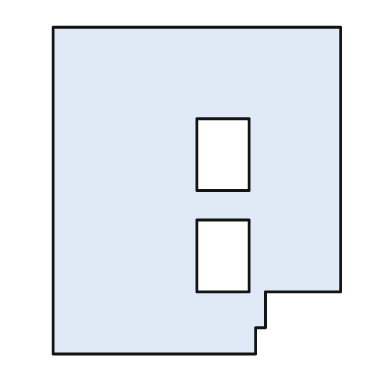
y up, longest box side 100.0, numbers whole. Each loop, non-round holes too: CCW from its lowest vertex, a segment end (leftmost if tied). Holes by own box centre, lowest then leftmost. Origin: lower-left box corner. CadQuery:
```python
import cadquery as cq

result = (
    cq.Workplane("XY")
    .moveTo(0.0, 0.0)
    .lineTo(62.0, 0.0)
    .lineTo(62.0, 8.0)
    .lineTo(65.0, 8.0)
    .lineTo(65.0, 19.0)
    .lineTo(88.0, 19.0)
    .lineTo(88.0, 100.0)
    .lineTo(0.0, 100.0)
    .close()
    .moveTo(44.0, 19.0)
    .lineTo(60.0, 19.0)
    .lineTo(60.0, 41.0)
    .lineTo(44.0, 41.0)
    .close()
    .moveTo(44.0, 50.0)
    .lineTo(60.0, 50.0)
    .lineTo(60.0, 72.0)
    .lineTo(44.0, 72.0)
    .close()
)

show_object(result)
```